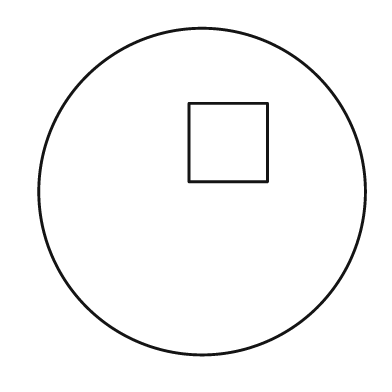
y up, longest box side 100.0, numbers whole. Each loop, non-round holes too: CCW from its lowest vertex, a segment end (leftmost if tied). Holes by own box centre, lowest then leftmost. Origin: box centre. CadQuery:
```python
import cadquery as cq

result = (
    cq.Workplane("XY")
    .moveTo(0.0, 0.0)
    .circle(50.0)
    .moveTo(-4.0, 3.0)
    .lineTo(20.0, 3.0)
    .lineTo(20.0, 27.0)
    .lineTo(-4.0, 27.0)
    .close()
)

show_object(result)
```